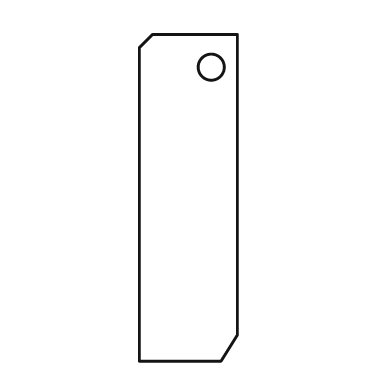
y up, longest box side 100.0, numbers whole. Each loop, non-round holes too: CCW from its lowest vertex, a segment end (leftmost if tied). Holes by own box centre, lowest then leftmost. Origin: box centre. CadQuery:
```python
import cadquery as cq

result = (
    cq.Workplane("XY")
    .moveTo(-15.0, -50.0)
    .lineTo(10.0, -50.0)
    .lineTo(15.0, -42.0)
    .lineTo(15.0, 50.0)
    .lineTo(-11.0, 50.0)
    .lineTo(-15.0, 46.0)
    .close()
    .moveTo(7.0, 40.0)
    .circle(4.0)
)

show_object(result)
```